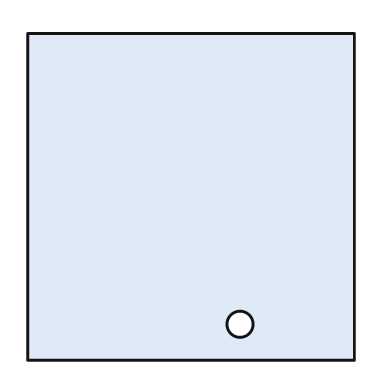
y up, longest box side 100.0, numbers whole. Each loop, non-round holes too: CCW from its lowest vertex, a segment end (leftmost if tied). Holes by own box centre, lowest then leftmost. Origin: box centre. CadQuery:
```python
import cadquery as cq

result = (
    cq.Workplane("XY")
    .moveTo(-50.0, -50.0)
    .lineTo(50.0, -50.0)
    .lineTo(50.0, 50.0)
    .lineTo(-50.0, 50.0)
    .close()
    .moveTo(15.0, -39.0)
    .circle(4.0)
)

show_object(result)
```